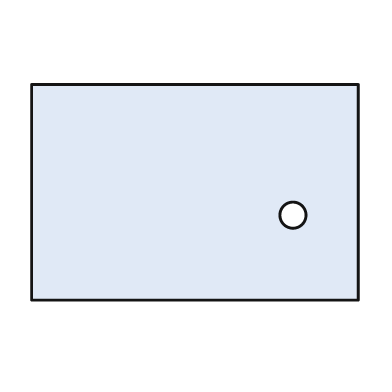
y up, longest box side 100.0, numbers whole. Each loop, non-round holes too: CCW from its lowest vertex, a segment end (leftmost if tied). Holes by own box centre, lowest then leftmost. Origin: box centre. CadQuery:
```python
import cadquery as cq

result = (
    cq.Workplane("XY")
    .moveTo(-50.0, -33.0)
    .lineTo(50.0, -33.0)
    .lineTo(50.0, 33.0)
    .lineTo(-50.0, 33.0)
    .close()
    .moveTo(30.0, -7.0)
    .circle(4.0)
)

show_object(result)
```